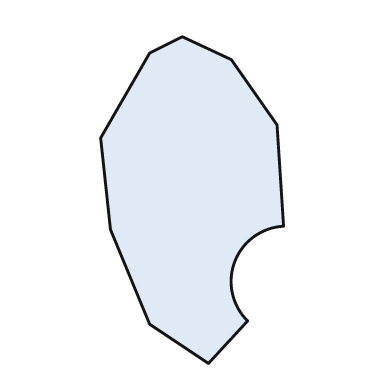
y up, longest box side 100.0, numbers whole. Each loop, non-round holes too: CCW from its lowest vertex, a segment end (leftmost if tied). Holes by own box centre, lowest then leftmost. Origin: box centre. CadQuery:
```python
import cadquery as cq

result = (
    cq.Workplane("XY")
    .moveTo(5.0, -50.0)
    .lineTo(17.0, -37.0)
    .threePointArc((13.0, -19.0), (28.0, -8.0))
    .lineTo(26.0, 23.0)
    .lineTo(12.0, 43.0)
    .lineTo(-3.0, 50.0)
    .lineTo(-13.0, 45.0)
    .lineTo(-28.0, 19.0)
    .lineTo(-25.0, -9.0)
    .lineTo(-13.0, -38.0)
    .close()
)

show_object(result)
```